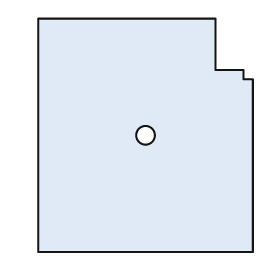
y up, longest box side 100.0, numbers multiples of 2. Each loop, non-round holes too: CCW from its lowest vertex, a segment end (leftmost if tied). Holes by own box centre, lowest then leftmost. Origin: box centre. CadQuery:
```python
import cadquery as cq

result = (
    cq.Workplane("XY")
    .moveTo(-46.0, -50.0)
    .lineTo(46.0, -50.0)
    .lineTo(46.0, 24.0)
    .lineTo(42.0, 24.0)
    .lineTo(42.0, 28.0)
    .lineTo(30.0, 28.0)
    .lineTo(30.0, 50.0)
    .lineTo(-46.0, 50.0)
    .close()
    .moveTo(0.0, 0.0)
    .circle(4.0)
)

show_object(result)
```